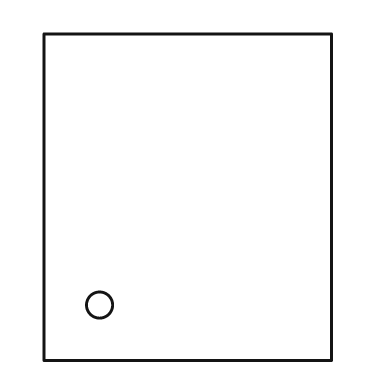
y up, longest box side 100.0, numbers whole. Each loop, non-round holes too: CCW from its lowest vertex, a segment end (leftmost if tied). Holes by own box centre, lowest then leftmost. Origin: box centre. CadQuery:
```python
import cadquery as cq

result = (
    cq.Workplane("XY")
    .moveTo(-44.0, -50.0)
    .lineTo(44.0, -50.0)
    .lineTo(44.0, 50.0)
    .lineTo(-44.0, 50.0)
    .close()
    .moveTo(-27.0, -33.0)
    .circle(4.0)
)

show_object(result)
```